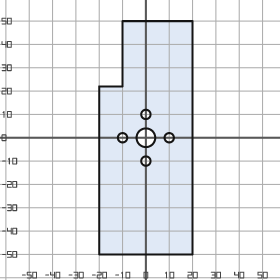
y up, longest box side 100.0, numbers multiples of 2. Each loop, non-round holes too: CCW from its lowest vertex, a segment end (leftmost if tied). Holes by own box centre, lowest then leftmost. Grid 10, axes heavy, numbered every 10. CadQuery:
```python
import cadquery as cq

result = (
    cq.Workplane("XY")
    .moveTo(-20.0, -50.0)
    .lineTo(20.0, -50.0)
    .lineTo(20.0, 50.0)
    .lineTo(-10.0, 50.0)
    .lineTo(-10.0, 22.0)
    .lineTo(-20.0, 22.0)
    .close()
    .moveTo(0.0, -10.0)
    .circle(2.0)
    .moveTo(-10.0, 0.0)
    .circle(2.0)
    .moveTo(0.0, 0.0)
    .circle(4.0)
    .moveTo(10.0, 0.0)
    .circle(2.0)
    .moveTo(0.0, 10.0)
    .circle(2.0)
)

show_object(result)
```